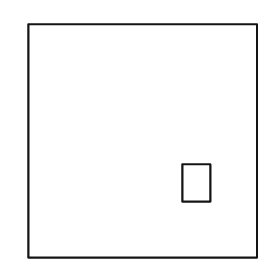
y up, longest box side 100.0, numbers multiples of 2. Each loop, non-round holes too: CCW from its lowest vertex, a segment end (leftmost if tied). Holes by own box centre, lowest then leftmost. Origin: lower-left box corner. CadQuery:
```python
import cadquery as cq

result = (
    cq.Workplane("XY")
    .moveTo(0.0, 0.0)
    .lineTo(98.0, 0.0)
    .lineTo(98.0, 100.0)
    .lineTo(0.0, 100.0)
    .close()
    .moveTo(66.0, 24.0)
    .lineTo(78.0, 24.0)
    .lineTo(78.0, 40.0)
    .lineTo(66.0, 40.0)
    .close()
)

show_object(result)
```